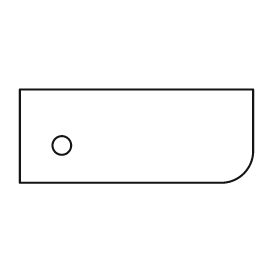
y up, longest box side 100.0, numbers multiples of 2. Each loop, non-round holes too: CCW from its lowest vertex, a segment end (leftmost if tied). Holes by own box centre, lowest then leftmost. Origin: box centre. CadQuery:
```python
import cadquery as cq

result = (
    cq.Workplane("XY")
    .moveTo(-50.0, -20.0)
    .lineTo(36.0, -20.0)
    .threePointArc((46.0, -16.0), (50.0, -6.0))
    .lineTo(50.0, 20.0)
    .lineTo(-50.0, 20.0)
    .close()
    .moveTo(-32.0, -4.0)
    .circle(4.0)
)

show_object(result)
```